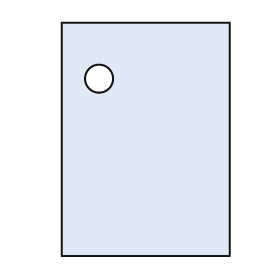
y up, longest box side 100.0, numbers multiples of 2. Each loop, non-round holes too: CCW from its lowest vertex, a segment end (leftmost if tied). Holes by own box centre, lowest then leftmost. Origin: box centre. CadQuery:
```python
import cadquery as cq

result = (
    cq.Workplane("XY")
    .moveTo(-36.0, -50.0)
    .lineTo(36.0, -50.0)
    .lineTo(36.0, 50.0)
    .lineTo(-36.0, 50.0)
    .close()
    .moveTo(-20.0, 26.0)
    .circle(6.0)
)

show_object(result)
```